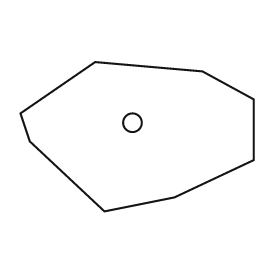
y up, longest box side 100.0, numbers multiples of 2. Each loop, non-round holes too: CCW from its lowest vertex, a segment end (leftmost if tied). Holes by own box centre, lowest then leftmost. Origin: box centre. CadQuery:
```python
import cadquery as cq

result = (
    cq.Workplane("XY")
    .moveTo(-14.0, -32.0)
    .lineTo(16.0, -26.0)
    .lineTo(50.0, -10.0)
    .lineTo(50.0, 16.0)
    .lineTo(28.0, 28.0)
    .lineTo(-18.0, 32.0)
    .lineTo(-50.0, 10.0)
    .lineTo(-46.0, -2.0)
    .close()
    .moveTo(-2.0, 6.0)
    .circle(4.0)
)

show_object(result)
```